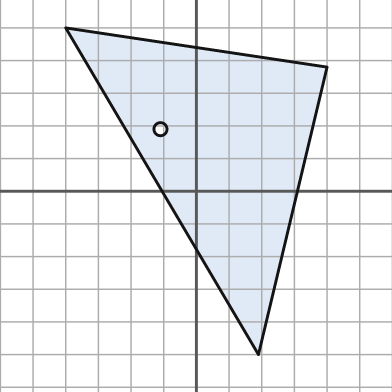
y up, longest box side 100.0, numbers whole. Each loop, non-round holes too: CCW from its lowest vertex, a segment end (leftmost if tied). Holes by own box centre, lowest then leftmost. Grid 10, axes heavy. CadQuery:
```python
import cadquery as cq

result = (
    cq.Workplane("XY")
    .moveTo(19.0, -50.0)
    .lineTo(40.0, 38.0)
    .lineTo(-40.0, 50.0)
    .close()
    .moveTo(-11.0, 19.0)
    .circle(2.0)
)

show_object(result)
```